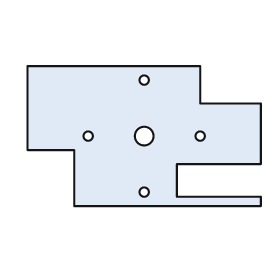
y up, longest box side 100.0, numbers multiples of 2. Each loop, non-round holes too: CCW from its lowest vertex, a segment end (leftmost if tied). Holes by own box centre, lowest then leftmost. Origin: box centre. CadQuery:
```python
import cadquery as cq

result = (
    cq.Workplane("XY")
    .moveTo(-30.0, -30.0)
    .lineTo(50.0, -30.0)
    .lineTo(50.0, -26.0)
    .lineTo(14.0, -26.0)
    .lineTo(14.0, -12.0)
    .lineTo(50.0, -12.0)
    .lineTo(50.0, 14.0)
    .lineTo(24.0, 14.0)
    .lineTo(24.0, 30.0)
    .lineTo(-50.0, 30.0)
    .lineTo(-50.0, -6.0)
    .lineTo(-30.0, -6.0)
    .close()
    .moveTo(0.0, -24.0)
    .circle(2.0)
    .moveTo(-24.0, 0.0)
    .circle(2.0)
    .moveTo(0.0, 0.0)
    .circle(4.0)
    .moveTo(24.0, 0.0)
    .circle(2.0)
    .moveTo(0.0, 24.0)
    .circle(2.0)
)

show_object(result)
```